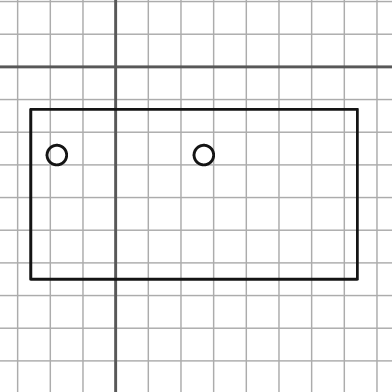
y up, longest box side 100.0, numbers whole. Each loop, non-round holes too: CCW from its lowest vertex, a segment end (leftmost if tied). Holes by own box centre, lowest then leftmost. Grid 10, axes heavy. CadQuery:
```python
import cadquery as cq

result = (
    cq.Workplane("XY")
    .moveTo(-26.0, -65.0)
    .lineTo(74.0, -65.0)
    .lineTo(74.0, -13.0)
    .lineTo(-26.0, -13.0)
    .close()
    .moveTo(-18.0, -27.0)
    .circle(3.0)
    .moveTo(27.0, -27.0)
    .circle(3.0)
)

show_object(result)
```